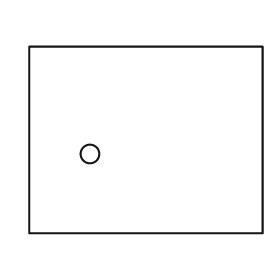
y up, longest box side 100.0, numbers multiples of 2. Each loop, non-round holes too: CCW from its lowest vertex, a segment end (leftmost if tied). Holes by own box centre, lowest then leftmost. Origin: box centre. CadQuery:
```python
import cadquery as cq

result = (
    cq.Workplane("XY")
    .moveTo(-50.0, -40.0)
    .lineTo(50.0, -40.0)
    .lineTo(50.0, 40.0)
    .lineTo(-50.0, 40.0)
    .close()
    .moveTo(-24.0, -6.0)
    .circle(4.0)
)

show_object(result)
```